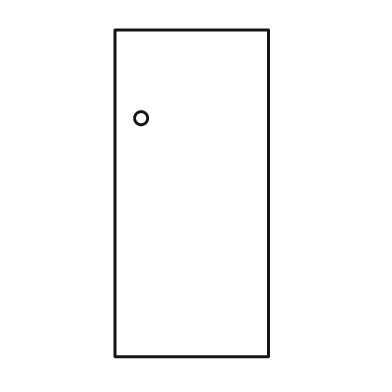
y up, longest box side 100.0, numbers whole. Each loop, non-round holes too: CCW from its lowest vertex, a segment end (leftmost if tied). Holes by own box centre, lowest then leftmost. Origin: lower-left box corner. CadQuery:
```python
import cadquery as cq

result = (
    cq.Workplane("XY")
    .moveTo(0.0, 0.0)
    .lineTo(47.0, 0.0)
    .lineTo(47.0, 100.0)
    .lineTo(0.0, 100.0)
    .close()
    .moveTo(8.0, 73.0)
    .circle(2.0)
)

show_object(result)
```